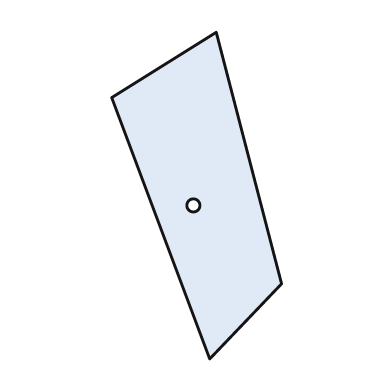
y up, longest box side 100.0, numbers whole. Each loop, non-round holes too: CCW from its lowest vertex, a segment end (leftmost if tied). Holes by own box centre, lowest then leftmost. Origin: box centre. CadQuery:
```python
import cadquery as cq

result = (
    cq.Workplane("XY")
    .moveTo(4.0, -50.0)
    .lineTo(26.0, -27.0)
    .lineTo(6.0, 50.0)
    .lineTo(-26.0, 30.0)
    .close()
    .moveTo(-1.0, -3.0)
    .circle(2.0)
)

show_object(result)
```